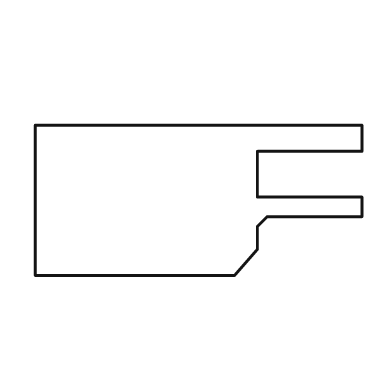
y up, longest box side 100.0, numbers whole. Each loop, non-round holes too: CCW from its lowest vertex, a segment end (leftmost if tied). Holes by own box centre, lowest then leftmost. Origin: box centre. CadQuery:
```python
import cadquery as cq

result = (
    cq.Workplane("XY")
    .moveTo(-50.0, -23.0)
    .lineTo(11.0, -23.0)
    .lineTo(18.0, -15.0)
    .lineTo(18.0, -8.0)
    .lineTo(21.0, -5.0)
    .lineTo(50.0, -5.0)
    .lineTo(50.0, 1.0)
    .lineTo(18.0, 1.0)
    .lineTo(18.0, 15.0)
    .lineTo(50.0, 15.0)
    .lineTo(50.0, 23.0)
    .lineTo(-50.0, 23.0)
    .close()
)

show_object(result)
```